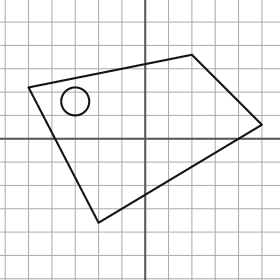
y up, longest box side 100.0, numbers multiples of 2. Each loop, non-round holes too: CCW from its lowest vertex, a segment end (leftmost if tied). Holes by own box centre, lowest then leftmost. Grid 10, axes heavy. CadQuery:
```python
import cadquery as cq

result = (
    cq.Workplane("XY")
    .moveTo(-20.0, -36.0)
    .lineTo(50.0, 6.0)
    .lineTo(20.0, 36.0)
    .lineTo(-50.0, 22.0)
    .close()
    .moveTo(-30.0, 16.0)
    .circle(6.0)
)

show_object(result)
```